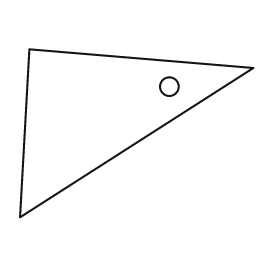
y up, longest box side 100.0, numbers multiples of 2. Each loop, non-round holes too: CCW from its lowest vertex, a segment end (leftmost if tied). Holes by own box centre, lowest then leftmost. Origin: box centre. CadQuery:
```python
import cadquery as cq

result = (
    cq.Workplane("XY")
    .moveTo(-50.0, -36.0)
    .lineTo(50.0, 28.0)
    .lineTo(-46.0, 36.0)
    .close()
    .moveTo(14.0, 20.0)
    .circle(4.0)
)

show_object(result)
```